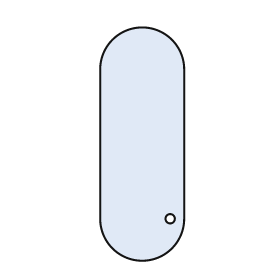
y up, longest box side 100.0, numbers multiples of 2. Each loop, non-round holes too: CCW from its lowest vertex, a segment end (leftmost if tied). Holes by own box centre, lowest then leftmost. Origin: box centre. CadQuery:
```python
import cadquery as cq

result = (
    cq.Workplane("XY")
    .moveTo(-18.0, -32.0)
    .threePointArc((0.0, -50.0), (18.0, -32.0))
    .lineTo(18.0, 32.0)
    .threePointArc((0.0, 50.0), (-18.0, 32.0))
    .close()
    .moveTo(12.0, -32.0)
    .circle(2.0)
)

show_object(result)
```